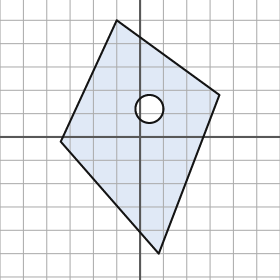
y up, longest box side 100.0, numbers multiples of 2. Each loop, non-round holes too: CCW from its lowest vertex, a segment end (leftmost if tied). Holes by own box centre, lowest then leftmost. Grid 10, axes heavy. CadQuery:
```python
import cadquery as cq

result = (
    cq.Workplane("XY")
    .moveTo(8.0, -50.0)
    .lineTo(34.0, 18.0)
    .lineTo(-10.0, 50.0)
    .lineTo(-34.0, -2.0)
    .close()
    .moveTo(4.0, 12.0)
    .circle(6.0)
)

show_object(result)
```